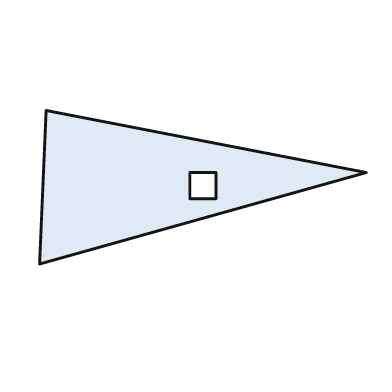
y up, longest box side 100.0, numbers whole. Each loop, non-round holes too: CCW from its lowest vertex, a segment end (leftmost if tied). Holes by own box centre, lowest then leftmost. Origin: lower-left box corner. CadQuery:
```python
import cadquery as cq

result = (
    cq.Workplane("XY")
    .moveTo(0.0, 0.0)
    .lineTo(100.0, 28.0)
    .lineTo(2.0, 47.0)
    .close()
    .moveTo(46.0, 20.0)
    .lineTo(54.0, 20.0)
    .lineTo(54.0, 28.0)
    .lineTo(46.0, 28.0)
    .close()
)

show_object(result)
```